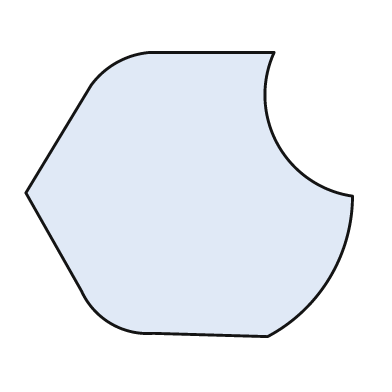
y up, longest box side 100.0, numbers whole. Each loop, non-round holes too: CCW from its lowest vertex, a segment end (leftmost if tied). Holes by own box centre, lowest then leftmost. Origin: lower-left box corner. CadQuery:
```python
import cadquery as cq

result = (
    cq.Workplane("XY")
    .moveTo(74.0, 0.0)
    .threePointArc((93.0, 18.0), (100.0, 43.0))
    .threePointArc((77.0, 59.0), (76.0, 87.0))
    .lineTo(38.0, 87.0)
    .threePointArc((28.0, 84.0), (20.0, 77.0))
    .lineTo(0.0, 44.0)
    .lineTo(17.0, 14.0)
    .threePointArc((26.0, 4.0), (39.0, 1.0))
    .close()
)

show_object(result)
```